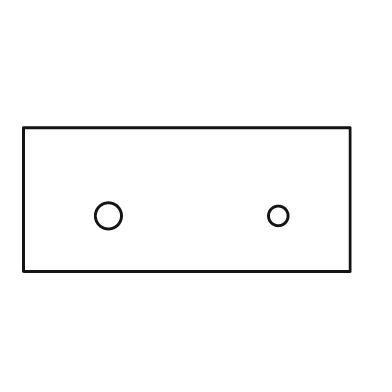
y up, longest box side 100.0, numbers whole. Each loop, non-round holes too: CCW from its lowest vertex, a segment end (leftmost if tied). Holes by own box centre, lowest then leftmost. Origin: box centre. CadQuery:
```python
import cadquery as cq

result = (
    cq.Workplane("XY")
    .moveTo(-50.0, -22.0)
    .lineTo(50.0, -22.0)
    .lineTo(50.0, 22.0)
    .lineTo(-50.0, 22.0)
    .close()
    .moveTo(-24.0, -5.0)
    .circle(4.0)
    .moveTo(28.0, -5.0)
    .circle(3.0)
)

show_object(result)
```